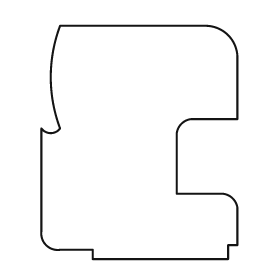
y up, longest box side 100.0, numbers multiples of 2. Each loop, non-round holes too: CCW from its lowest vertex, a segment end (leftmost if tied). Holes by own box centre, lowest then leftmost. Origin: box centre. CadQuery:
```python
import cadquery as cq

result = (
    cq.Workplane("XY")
    .moveTo(-20.0, -50.0)
    .lineTo(38.0, -50.0)
    .lineTo(38.0, -44.0)
    .lineTo(42.0, -44.0)
    .lineTo(42.0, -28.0)
    .threePointArc((40.0, -24.0), (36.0, -22.0))
    .lineTo(16.0, -22.0)
    .lineTo(16.0, 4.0)
    .threePointArc((18.0, 8.0), (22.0, 10.0))
    .lineTo(42.0, 10.0)
    .lineTo(42.0, 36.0)
    .threePointArc((38.0, 46.0), (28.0, 50.0))
    .lineTo(-34.0, 50.0)
    .threePointArc((-38.0, 28.0), (-34.0, 6.0))
    .threePointArc((-38.0, 4.0), (-42.0, 6.0))
    .lineTo(-42.0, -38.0)
    .threePointArc((-40.0, -44.0), (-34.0, -46.0))
    .lineTo(-20.0, -46.0)
    .close()
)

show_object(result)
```